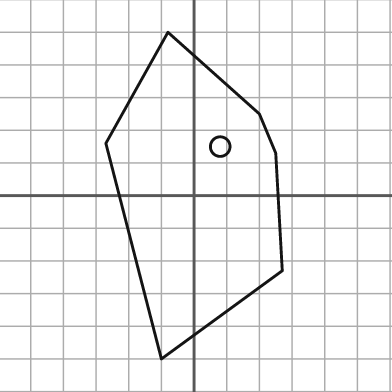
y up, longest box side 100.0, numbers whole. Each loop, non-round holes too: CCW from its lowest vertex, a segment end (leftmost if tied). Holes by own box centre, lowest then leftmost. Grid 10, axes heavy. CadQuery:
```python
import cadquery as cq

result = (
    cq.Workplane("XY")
    .moveTo(-10.0, -50.0)
    .lineTo(27.0, -23.0)
    .lineTo(25.0, 13.0)
    .lineTo(20.0, 25.0)
    .lineTo(-8.0, 50.0)
    .lineTo(-27.0, 16.0)
    .close()
    .moveTo(8.0, 15.0)
    .circle(3.0)
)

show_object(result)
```